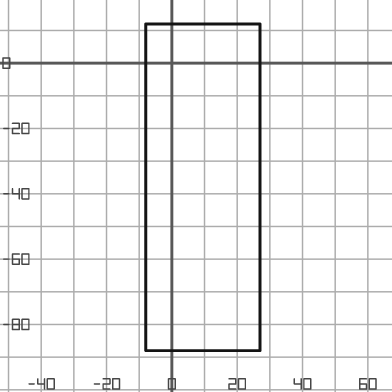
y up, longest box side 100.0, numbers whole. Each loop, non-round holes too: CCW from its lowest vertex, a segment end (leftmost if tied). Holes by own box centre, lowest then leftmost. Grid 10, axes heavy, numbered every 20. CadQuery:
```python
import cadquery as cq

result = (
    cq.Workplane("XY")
    .moveTo(-8.0, -88.0)
    .lineTo(27.0, -88.0)
    .lineTo(27.0, 12.0)
    .lineTo(-8.0, 12.0)
    .close()
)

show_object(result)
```